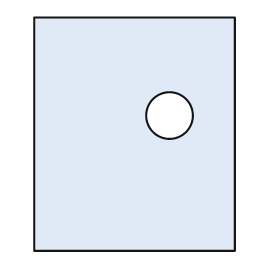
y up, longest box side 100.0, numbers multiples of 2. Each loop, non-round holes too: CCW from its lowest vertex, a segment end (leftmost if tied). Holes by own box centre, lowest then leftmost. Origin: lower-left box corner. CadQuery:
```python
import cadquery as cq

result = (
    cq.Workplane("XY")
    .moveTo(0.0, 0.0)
    .lineTo(86.0, 0.0)
    .lineTo(86.0, 100.0)
    .lineTo(0.0, 100.0)
    .close()
    .moveTo(58.0, 58.0)
    .circle(10.0)
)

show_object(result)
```